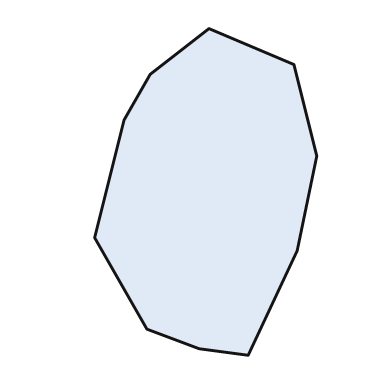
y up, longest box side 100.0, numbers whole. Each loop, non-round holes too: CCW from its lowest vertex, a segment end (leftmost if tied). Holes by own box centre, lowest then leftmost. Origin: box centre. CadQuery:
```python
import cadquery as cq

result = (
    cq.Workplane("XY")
    .moveTo(13.0, -50.0)
    .lineTo(28.0, -18.0)
    .lineTo(34.0, 11.0)
    .lineTo(27.0, 39.0)
    .lineTo(1.0, 50.0)
    .lineTo(-17.0, 36.0)
    .lineTo(-25.0, 22.0)
    .lineTo(-34.0, -14.0)
    .lineTo(-18.0, -42.0)
    .lineTo(-2.0, -48.0)
    .close()
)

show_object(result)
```